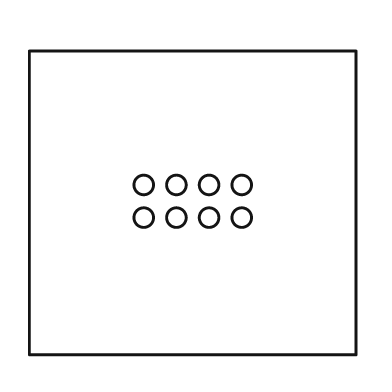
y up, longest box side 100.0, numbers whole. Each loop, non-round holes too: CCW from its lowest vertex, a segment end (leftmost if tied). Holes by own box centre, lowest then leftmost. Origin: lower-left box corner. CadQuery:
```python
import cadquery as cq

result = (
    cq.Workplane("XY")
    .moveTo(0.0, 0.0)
    .lineTo(100.0, 0.0)
    .lineTo(100.0, 93.0)
    .lineTo(0.0, 93.0)
    .close()
    .moveTo(35.0, 42.0)
    .circle(3.0)
    .moveTo(45.0, 42.0)
    .circle(3.0)
    .moveTo(55.0, 42.0)
    .circle(3.0)
    .moveTo(65.0, 42.0)
    .circle(3.0)
    .moveTo(35.0, 52.0)
    .circle(3.0)
    .moveTo(45.0, 52.0)
    .circle(3.0)
    .moveTo(55.0, 52.0)
    .circle(3.0)
    .moveTo(65.0, 52.0)
    .circle(3.0)
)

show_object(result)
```